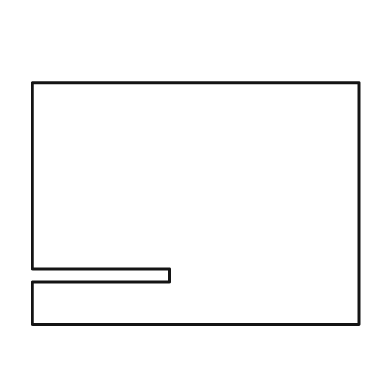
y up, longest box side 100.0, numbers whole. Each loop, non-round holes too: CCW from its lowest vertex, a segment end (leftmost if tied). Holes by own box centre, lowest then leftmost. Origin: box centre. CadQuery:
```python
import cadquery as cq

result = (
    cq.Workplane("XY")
    .moveTo(-50.0, -37.0)
    .lineTo(50.0, -37.0)
    .lineTo(50.0, 37.0)
    .lineTo(-50.0, 37.0)
    .lineTo(-50.0, -20.0)
    .lineTo(-8.0, -20.0)
    .lineTo(-8.0, -24.0)
    .lineTo(-50.0, -24.0)
    .close()
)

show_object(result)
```